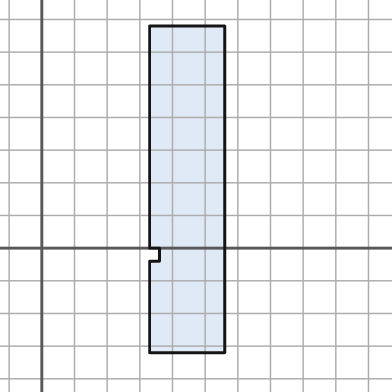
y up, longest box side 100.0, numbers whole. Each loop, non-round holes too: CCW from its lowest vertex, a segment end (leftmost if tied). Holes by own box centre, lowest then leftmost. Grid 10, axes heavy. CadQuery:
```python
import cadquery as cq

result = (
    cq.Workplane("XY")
    .moveTo(33.0, -32.0)
    .lineTo(56.0, -32.0)
    .lineTo(56.0, 68.0)
    .lineTo(33.0, 68.0)
    .lineTo(33.0, 0.0)
    .lineTo(36.0, 0.0)
    .lineTo(36.0, -4.0)
    .lineTo(33.0, -4.0)
    .close()
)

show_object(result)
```